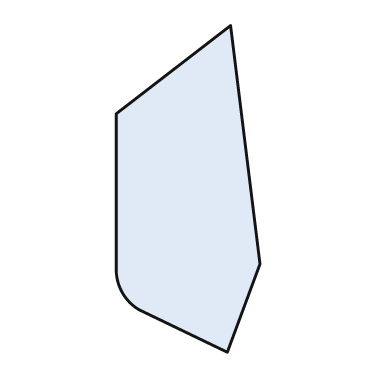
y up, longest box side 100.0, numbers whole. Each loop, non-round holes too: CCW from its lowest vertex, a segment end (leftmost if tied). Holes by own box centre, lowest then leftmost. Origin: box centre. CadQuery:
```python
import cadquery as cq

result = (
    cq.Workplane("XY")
    .moveTo(12.0, -50.0)
    .lineTo(22.0, -23.0)
    .lineTo(13.0, 50.0)
    .lineTo(-22.0, 23.0)
    .lineTo(-22.0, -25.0)
    .threePointArc((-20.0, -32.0), (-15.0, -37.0))
    .close()
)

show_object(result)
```